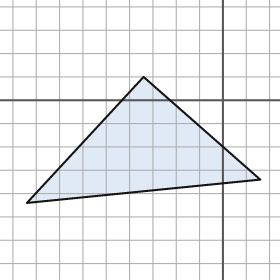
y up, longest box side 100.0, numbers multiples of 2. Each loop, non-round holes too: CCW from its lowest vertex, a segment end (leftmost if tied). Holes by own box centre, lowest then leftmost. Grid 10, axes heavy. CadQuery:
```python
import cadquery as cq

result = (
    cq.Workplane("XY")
    .moveTo(-84.0, -44.0)
    .lineTo(16.0, -34.0)
    .lineTo(-34.0, 10.0)
    .close()
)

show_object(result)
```